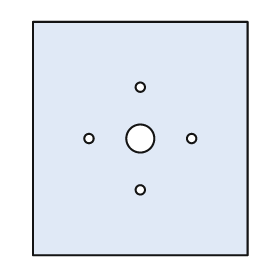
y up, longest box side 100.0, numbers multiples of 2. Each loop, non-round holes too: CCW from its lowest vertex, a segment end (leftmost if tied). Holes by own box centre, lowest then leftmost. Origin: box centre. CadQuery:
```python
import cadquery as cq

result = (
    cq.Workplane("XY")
    .moveTo(-46.0, -50.0)
    .lineTo(46.0, -50.0)
    .lineTo(46.0, 50.0)
    .lineTo(-46.0, 50.0)
    .close()
    .moveTo(0.0, -22.0)
    .circle(2.0)
    .moveTo(-22.0, 0.0)
    .circle(2.0)
    .moveTo(0.0, 0.0)
    .circle(6.0)
    .moveTo(22.0, 0.0)
    .circle(2.0)
    .moveTo(0.0, 22.0)
    .circle(2.0)
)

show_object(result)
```